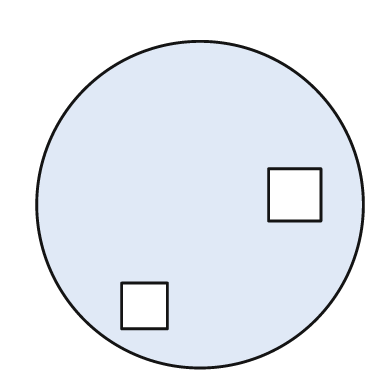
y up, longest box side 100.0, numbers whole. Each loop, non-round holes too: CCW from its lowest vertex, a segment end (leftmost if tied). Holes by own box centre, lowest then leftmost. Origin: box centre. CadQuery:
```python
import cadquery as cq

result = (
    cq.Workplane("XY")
    .moveTo(0.0, 0.0)
    .circle(50.0)
    .moveTo(-24.0, -38.0)
    .lineTo(-10.0, -38.0)
    .lineTo(-10.0, -24.0)
    .lineTo(-24.0, -24.0)
    .close()
    .moveTo(21.0, -5.0)
    .lineTo(37.0, -5.0)
    .lineTo(37.0, 11.0)
    .lineTo(21.0, 11.0)
    .close()
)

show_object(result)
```